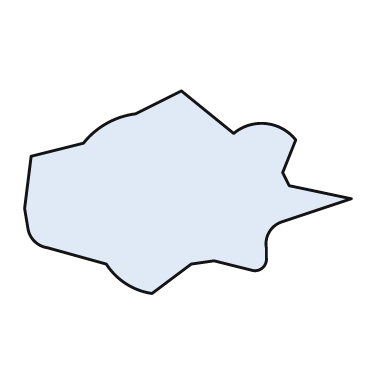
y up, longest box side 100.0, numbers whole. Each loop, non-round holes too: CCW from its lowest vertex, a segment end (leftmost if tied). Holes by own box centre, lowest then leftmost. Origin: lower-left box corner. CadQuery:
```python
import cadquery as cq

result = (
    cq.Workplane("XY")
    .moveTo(39.0, 0.0)
    .lineTo(51.0, 9.0)
    .lineTo(58.0, 10.0)
    .lineTo(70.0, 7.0)
    .threePointArc((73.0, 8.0), (74.0, 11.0))
    .lineTo(74.0, 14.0)
    .threePointArc((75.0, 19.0), (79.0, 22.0))
    .lineTo(100.0, 29.0)
    .lineTo(81.0, 33.0)
    .lineTo(79.0, 37.0)
    .lineTo(83.0, 47.0)
    .threePointArc((74.0, 52.0), (64.0, 49.0))
    .lineTo(48.0, 62.0)
    .lineTo(34.0, 55.0)
    .threePointArc((25.0, 52.0), (18.0, 46.0))
    .lineTo(2.0, 42.0)
    .lineTo(0.0, 26.0)
    .lineTo(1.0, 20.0)
    .threePointArc((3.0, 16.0), (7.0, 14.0))
    .lineTo(25.0, 9.0)
    .threePointArc((31.0, 3.0), (39.0, 0.0))
    .close()
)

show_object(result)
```